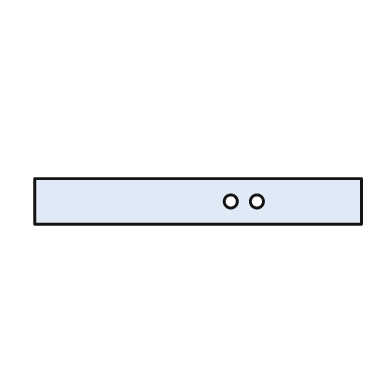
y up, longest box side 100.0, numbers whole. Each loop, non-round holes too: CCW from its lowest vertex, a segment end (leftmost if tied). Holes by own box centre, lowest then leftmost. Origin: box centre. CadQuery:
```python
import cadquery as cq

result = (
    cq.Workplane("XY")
    .moveTo(-50.0, -7.0)
    .lineTo(50.0, -7.0)
    .lineTo(50.0, 7.0)
    .lineTo(-50.0, 7.0)
    .close()
    .moveTo(10.0, 0.0)
    .circle(2.0)
    .moveTo(18.0, 0.0)
    .circle(2.0)
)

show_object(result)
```